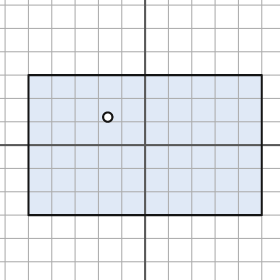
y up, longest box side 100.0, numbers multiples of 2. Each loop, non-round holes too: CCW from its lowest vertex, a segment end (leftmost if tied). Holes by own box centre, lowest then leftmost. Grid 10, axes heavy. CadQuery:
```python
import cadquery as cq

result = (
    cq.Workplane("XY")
    .moveTo(-50.0, -30.0)
    .lineTo(50.0, -30.0)
    .lineTo(50.0, 30.0)
    .lineTo(-50.0, 30.0)
    .close()
    .moveTo(-16.0, 12.0)
    .circle(2.0)
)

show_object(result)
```